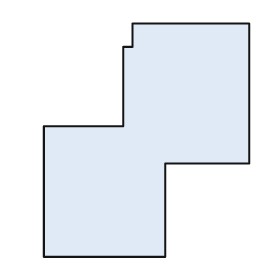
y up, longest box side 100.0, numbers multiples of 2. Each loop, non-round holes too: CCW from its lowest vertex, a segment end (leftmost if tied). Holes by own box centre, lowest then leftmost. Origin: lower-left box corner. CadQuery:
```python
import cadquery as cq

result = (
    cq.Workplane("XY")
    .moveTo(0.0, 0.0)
    .lineTo(52.0, 0.0)
    .lineTo(52.0, 40.0)
    .lineTo(88.0, 40.0)
    .lineTo(88.0, 100.0)
    .lineTo(38.0, 100.0)
    .lineTo(38.0, 90.0)
    .lineTo(34.0, 90.0)
    .lineTo(34.0, 56.0)
    .lineTo(0.0, 56.0)
    .close()
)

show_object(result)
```